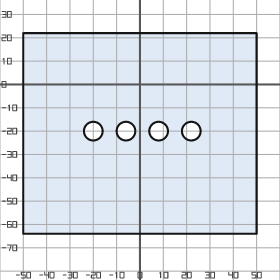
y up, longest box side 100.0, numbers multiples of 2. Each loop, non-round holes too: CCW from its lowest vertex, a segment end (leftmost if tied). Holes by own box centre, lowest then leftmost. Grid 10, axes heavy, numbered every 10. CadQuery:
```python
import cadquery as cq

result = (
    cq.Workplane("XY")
    .moveTo(-50.0, -64.0)
    .lineTo(50.0, -64.0)
    .lineTo(50.0, 22.0)
    .lineTo(-50.0, 22.0)
    .close()
    .moveTo(-20.0, -20.0)
    .circle(4.0)
    .moveTo(-6.0, -20.0)
    .circle(4.0)
    .moveTo(8.0, -20.0)
    .circle(4.0)
    .moveTo(22.0, -20.0)
    .circle(4.0)
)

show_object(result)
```